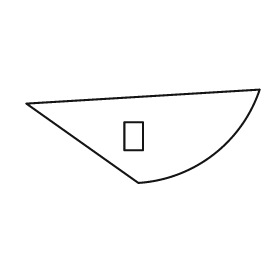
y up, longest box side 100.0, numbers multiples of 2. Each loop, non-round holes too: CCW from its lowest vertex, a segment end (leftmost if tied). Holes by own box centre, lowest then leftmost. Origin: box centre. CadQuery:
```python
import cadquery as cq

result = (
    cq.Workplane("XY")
    .moveTo(-2.0, -20.0)
    .threePointArc((30.0, -8.0), (50.0, 20.0))
    .lineTo(-50.0, 14.0)
    .close()
    .moveTo(-8.0, -6.0)
    .lineTo(0.0, -6.0)
    .lineTo(0.0, 6.0)
    .lineTo(-8.0, 6.0)
    .close()
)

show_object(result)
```